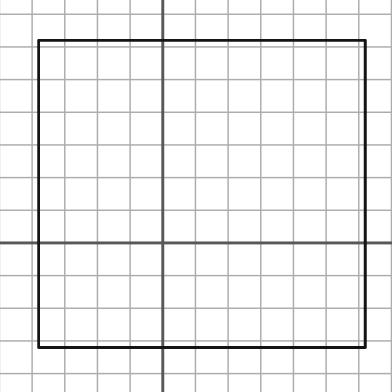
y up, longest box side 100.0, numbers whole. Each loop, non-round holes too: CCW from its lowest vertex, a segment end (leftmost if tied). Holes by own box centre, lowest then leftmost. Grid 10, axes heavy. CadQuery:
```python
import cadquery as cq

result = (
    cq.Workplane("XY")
    .moveTo(-38.0, -32.0)
    .lineTo(62.0, -32.0)
    .lineTo(62.0, 62.0)
    .lineTo(-38.0, 62.0)
    .close()
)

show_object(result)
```